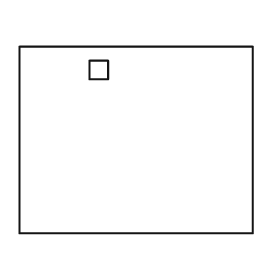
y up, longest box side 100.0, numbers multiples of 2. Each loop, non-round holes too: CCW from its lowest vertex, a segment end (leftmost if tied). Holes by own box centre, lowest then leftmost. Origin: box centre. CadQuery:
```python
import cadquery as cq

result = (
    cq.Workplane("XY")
    .moveTo(-50.0, -40.0)
    .lineTo(50.0, -40.0)
    .lineTo(50.0, 40.0)
    .lineTo(-50.0, 40.0)
    .close()
    .moveTo(-20.0, 26.0)
    .lineTo(-12.0, 26.0)
    .lineTo(-12.0, 34.0)
    .lineTo(-20.0, 34.0)
    .close()
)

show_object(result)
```